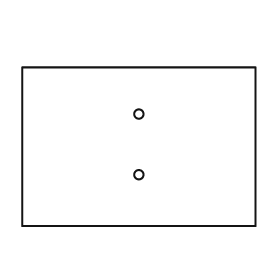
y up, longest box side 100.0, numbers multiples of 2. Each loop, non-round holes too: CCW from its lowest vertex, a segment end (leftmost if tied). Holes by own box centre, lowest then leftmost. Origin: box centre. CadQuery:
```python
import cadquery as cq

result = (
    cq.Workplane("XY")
    .moveTo(-50.0, -34.0)
    .lineTo(50.0, -34.0)
    .lineTo(50.0, 34.0)
    .lineTo(-50.0, 34.0)
    .close()
    .moveTo(0.0, -12.0)
    .circle(2.0)
    .moveTo(0.0, 14.0)
    .circle(2.0)
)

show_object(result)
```